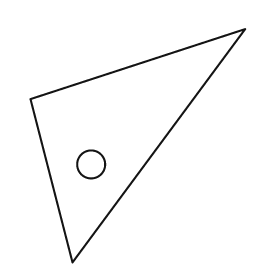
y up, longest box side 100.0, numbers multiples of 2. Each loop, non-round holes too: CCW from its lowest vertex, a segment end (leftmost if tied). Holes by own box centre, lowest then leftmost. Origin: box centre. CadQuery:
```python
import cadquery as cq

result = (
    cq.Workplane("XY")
    .moveTo(-28.0, -50.0)
    .lineTo(46.0, 50.0)
    .lineTo(-46.0, 20.0)
    .close()
    .moveTo(-20.0, -8.0)
    .circle(6.0)
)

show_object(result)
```